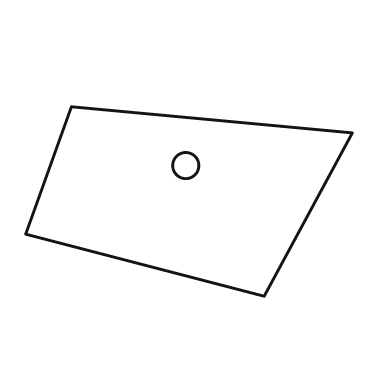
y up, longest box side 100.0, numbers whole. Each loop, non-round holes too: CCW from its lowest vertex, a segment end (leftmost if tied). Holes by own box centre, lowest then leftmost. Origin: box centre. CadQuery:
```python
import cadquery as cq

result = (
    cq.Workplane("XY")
    .moveTo(23.0, -29.0)
    .lineTo(50.0, 21.0)
    .lineTo(-36.0, 29.0)
    .lineTo(-50.0, -10.0)
    .close()
    .moveTo(-1.0, 11.0)
    .circle(4.0)
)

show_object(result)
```